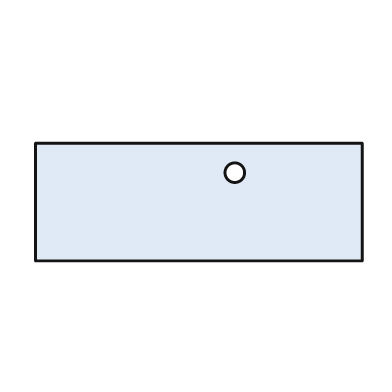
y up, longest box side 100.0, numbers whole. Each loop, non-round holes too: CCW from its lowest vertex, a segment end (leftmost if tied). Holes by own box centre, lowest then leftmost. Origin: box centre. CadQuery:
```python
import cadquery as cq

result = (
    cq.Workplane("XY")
    .moveTo(-50.0, -18.0)
    .lineTo(50.0, -18.0)
    .lineTo(50.0, 18.0)
    .lineTo(-50.0, 18.0)
    .close()
    .moveTo(11.0, 9.0)
    .circle(3.0)
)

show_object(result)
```